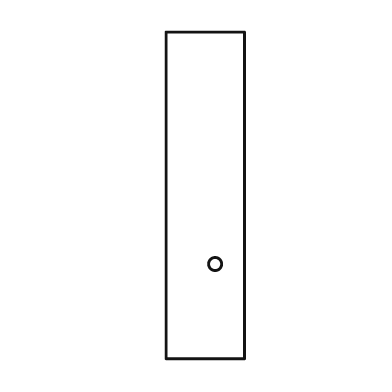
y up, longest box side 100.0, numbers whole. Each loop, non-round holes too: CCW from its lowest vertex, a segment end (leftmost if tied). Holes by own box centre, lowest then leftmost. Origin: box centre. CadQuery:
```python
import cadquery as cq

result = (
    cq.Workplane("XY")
    .moveTo(-12.0, -50.0)
    .lineTo(12.0, -50.0)
    .lineTo(12.0, 50.0)
    .lineTo(-12.0, 50.0)
    .close()
    .moveTo(3.0, -21.0)
    .circle(2.0)
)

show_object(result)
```